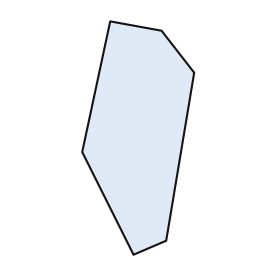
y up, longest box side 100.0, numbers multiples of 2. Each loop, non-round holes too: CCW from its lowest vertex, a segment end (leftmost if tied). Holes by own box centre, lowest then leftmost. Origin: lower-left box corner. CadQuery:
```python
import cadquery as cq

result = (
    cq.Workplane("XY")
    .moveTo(22.0, 0.0)
    .lineTo(36.0, 6.0)
    .lineTo(48.0, 78.0)
    .lineTo(34.0, 96.0)
    .lineTo(12.0, 100.0)
    .lineTo(0.0, 44.0)
    .close()
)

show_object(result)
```